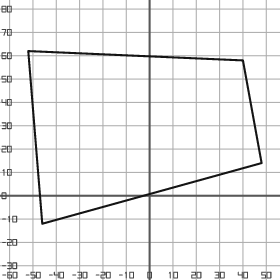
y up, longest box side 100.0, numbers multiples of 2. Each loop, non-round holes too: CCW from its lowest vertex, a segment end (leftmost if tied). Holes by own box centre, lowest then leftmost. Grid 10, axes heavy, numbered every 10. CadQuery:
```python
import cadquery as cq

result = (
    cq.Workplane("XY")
    .moveTo(-46.0, -12.0)
    .lineTo(48.0, 14.0)
    .lineTo(40.0, 58.0)
    .lineTo(-52.0, 62.0)
    .close()
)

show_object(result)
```